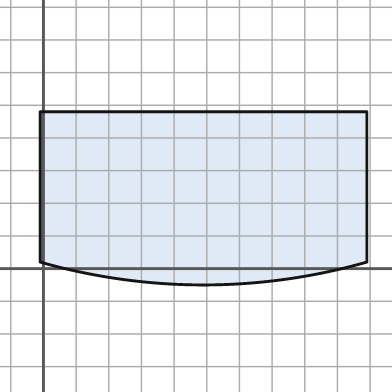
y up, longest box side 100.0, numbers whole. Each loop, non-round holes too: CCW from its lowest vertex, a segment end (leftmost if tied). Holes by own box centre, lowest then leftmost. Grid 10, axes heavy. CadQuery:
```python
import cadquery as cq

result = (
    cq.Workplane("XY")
    .moveTo(-1.0, 2.0)
    .threePointArc((49.0, -5.0), (99.0, 2.0))
    .lineTo(99.0, 48.0)
    .lineTo(-1.0, 48.0)
    .close()
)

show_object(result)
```